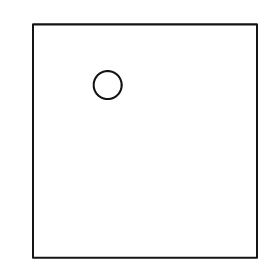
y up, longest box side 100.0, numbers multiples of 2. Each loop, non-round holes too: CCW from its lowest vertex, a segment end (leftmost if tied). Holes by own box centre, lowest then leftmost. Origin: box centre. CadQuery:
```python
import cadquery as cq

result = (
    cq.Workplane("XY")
    .moveTo(-48.0, -50.0)
    .lineTo(48.0, -50.0)
    .lineTo(48.0, 50.0)
    .lineTo(-48.0, 50.0)
    .close()
    .moveTo(-16.0, 24.0)
    .circle(6.0)
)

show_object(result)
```